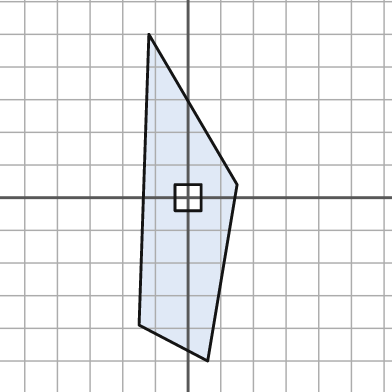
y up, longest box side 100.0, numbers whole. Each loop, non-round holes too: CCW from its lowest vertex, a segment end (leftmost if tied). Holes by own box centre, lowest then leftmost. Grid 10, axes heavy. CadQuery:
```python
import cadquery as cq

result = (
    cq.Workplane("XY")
    .moveTo(6.0, -50.0)
    .lineTo(15.0, 4.0)
    .lineTo(-12.0, 50.0)
    .lineTo(-15.0, -39.0)
    .close()
    .moveTo(-4.0, -4.0)
    .lineTo(4.0, -4.0)
    .lineTo(4.0, 4.0)
    .lineTo(-4.0, 4.0)
    .close()
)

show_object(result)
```